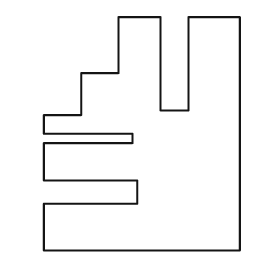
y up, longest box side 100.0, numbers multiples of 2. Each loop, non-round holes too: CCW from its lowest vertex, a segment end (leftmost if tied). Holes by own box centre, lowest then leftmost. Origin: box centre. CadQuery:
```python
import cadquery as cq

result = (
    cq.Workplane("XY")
    .moveTo(-42.0, -50.0)
    .lineTo(42.0, -50.0)
    .lineTo(42.0, 50.0)
    .lineTo(20.0, 50.0)
    .lineTo(20.0, 10.0)
    .lineTo(8.0, 10.0)
    .lineTo(8.0, 50.0)
    .lineTo(-10.0, 50.0)
    .lineTo(-10.0, 26.0)
    .lineTo(-26.0, 26.0)
    .lineTo(-26.0, 8.0)
    .lineTo(-42.0, 8.0)
    .lineTo(-42.0, 0.0)
    .lineTo(-4.0, 0.0)
    .lineTo(-4.0, -4.0)
    .lineTo(-42.0, -4.0)
    .lineTo(-42.0, -20.0)
    .lineTo(-2.0, -20.0)
    .lineTo(-2.0, -30.0)
    .lineTo(-42.0, -30.0)
    .close()
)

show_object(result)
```